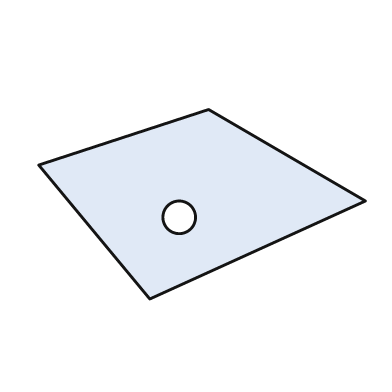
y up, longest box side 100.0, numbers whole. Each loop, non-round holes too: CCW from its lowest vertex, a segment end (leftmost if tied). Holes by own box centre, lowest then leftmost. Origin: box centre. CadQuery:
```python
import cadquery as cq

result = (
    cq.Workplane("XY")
    .moveTo(-16.0, -29.0)
    .lineTo(50.0, 1.0)
    .lineTo(2.0, 29.0)
    .lineTo(-50.0, 12.0)
    .close()
    .moveTo(-7.0, -4.0)
    .circle(5.0)
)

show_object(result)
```